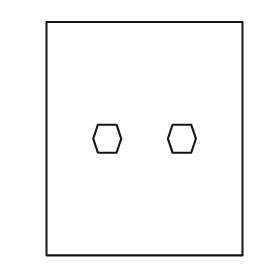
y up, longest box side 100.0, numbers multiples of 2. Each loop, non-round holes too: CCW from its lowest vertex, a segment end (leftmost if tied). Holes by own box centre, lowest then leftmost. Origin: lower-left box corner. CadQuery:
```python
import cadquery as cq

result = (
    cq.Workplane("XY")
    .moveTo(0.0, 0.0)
    .lineTo(84.0, 0.0)
    .lineTo(84.0, 100.0)
    .lineTo(0.0, 100.0)
    .close()
    .moveTo(22.0, 44.0)
    .lineTo(30.0, 44.0)
    .lineTo(32.0, 50.0)
    .lineTo(30.0, 56.0)
    .lineTo(22.0, 56.0)
    .lineTo(20.0, 50.0)
    .close()
    .moveTo(54.0, 44.0)
    .lineTo(62.0, 44.0)
    .lineTo(64.0, 50.0)
    .lineTo(62.0, 56.0)
    .lineTo(54.0, 56.0)
    .lineTo(52.0, 50.0)
    .close()
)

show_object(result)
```